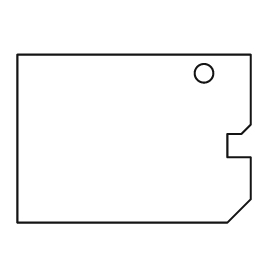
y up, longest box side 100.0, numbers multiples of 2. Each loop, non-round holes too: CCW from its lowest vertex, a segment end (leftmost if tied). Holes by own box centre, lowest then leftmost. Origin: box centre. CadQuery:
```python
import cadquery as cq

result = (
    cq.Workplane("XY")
    .moveTo(-50.0, -36.0)
    .lineTo(40.0, -36.0)
    .lineTo(50.0, -26.0)
    .lineTo(50.0, -8.0)
    .lineTo(40.0, -8.0)
    .lineTo(40.0, 2.0)
    .lineTo(46.0, 2.0)
    .lineTo(50.0, 6.0)
    .lineTo(50.0, 36.0)
    .lineTo(-50.0, 36.0)
    .close()
    .moveTo(30.0, 28.0)
    .circle(4.0)
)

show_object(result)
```